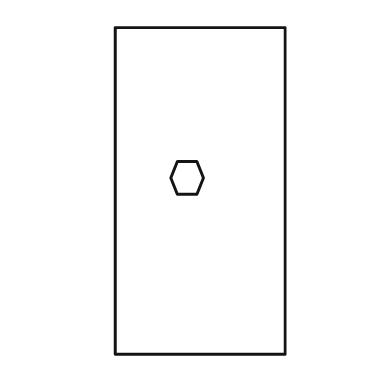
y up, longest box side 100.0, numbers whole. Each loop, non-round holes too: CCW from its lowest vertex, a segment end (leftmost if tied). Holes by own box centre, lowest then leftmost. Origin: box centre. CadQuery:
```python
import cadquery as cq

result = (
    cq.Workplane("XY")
    .moveTo(-26.0, -50.0)
    .lineTo(26.0, -50.0)
    .lineTo(26.0, 50.0)
    .lineTo(-26.0, 50.0)
    .close()
    .moveTo(-7.0, -1.0)
    .lineTo(-1.0, -1.0)
    .lineTo(1.0, 4.0)
    .lineTo(-1.0, 9.0)
    .lineTo(-7.0, 9.0)
    .lineTo(-9.0, 4.0)
    .close()
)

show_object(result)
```